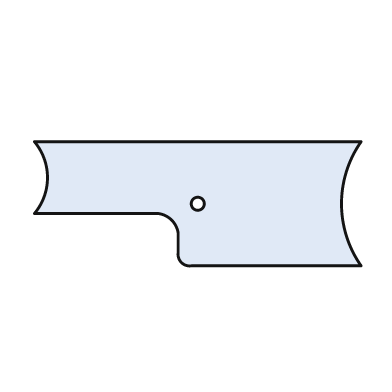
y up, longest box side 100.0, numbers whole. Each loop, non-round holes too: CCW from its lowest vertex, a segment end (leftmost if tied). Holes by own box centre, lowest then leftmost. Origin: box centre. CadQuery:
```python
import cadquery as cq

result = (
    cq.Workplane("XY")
    .moveTo(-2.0, -19.0)
    .lineTo(50.0, -19.0)
    .threePointArc((44.0, 0.0), (50.0, 19.0))
    .lineTo(-50.0, 19.0)
    .threePointArc((-46.0, 8.0), (-50.0, -3.0))
    .lineTo(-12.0, -3.0)
    .threePointArc((-8.0, -5.0), (-6.0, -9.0))
    .lineTo(-6.0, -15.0)
    .threePointArc((-5.0, -18.0), (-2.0, -19.0))
    .close()
    .moveTo(0.0, 0.0)
    .circle(2.0)
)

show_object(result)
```